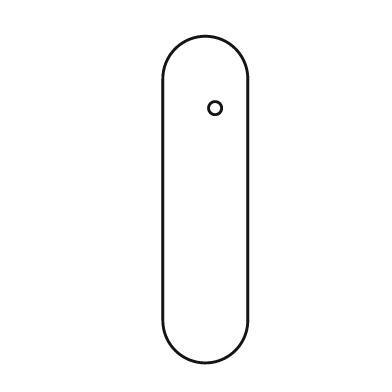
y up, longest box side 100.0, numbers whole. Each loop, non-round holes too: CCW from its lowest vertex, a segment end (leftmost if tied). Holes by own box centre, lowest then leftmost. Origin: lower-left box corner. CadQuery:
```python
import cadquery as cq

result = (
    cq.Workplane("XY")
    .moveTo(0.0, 13.0)
    .threePointArc((13.0, 0.0), (26.0, 13.0))
    .lineTo(26.0, 87.0)
    .threePointArc((13.0, 100.0), (0.0, 87.0))
    .close()
    .moveTo(16.0, 78.0)
    .circle(2.0)
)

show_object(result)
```